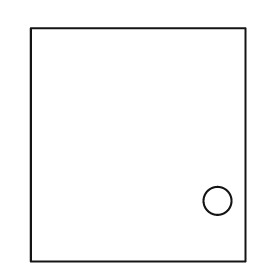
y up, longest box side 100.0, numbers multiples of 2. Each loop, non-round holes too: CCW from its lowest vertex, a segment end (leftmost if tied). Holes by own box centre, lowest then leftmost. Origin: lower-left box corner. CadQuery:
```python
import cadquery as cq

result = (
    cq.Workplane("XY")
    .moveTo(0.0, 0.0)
    .lineTo(92.0, 0.0)
    .lineTo(92.0, 100.0)
    .lineTo(0.0, 100.0)
    .close()
    .moveTo(80.0, 26.0)
    .circle(6.0)
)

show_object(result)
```